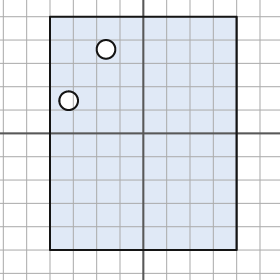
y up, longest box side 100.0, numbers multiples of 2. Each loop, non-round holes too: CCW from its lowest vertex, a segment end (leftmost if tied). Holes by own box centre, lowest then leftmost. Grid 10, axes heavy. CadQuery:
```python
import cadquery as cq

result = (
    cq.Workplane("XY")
    .moveTo(-40.0, -50.0)
    .lineTo(40.0, -50.0)
    .lineTo(40.0, 50.0)
    .lineTo(-40.0, 50.0)
    .close()
    .moveTo(-32.0, 14.0)
    .circle(4.0)
    .moveTo(-16.0, 36.0)
    .circle(4.0)
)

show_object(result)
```